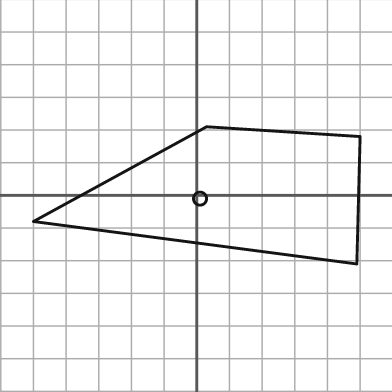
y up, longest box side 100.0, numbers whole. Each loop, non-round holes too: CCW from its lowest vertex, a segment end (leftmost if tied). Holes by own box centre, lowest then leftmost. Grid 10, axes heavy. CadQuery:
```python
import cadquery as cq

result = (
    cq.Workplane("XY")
    .moveTo(49.0, -21.0)
    .lineTo(50.0, 18.0)
    .lineTo(3.0, 21.0)
    .lineTo(-50.0, -8.0)
    .close()
    .moveTo(1.0, -1.0)
    .circle(2.0)
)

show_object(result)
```